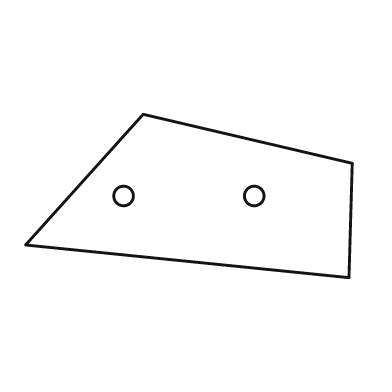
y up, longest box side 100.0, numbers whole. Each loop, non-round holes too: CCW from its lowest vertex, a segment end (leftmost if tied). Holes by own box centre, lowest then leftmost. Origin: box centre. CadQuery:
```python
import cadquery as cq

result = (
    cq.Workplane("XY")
    .moveTo(49.0, -25.0)
    .lineTo(50.0, 10.0)
    .lineTo(-14.0, 25.0)
    .lineTo(-50.0, -15.0)
    .close()
    .moveTo(-20.0, 0.0)
    .circle(3.0)
    .moveTo(20.0, 0.0)
    .circle(3.0)
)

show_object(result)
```